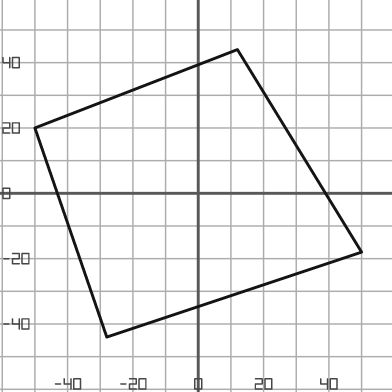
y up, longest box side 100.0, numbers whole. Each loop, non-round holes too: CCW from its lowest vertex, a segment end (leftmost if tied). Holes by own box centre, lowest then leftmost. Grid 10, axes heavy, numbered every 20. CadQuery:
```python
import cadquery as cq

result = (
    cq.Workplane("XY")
    .moveTo(-28.0, -44.0)
    .lineTo(50.0, -18.0)
    .lineTo(12.0, 44.0)
    .lineTo(-50.0, 20.0)
    .close()
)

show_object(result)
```